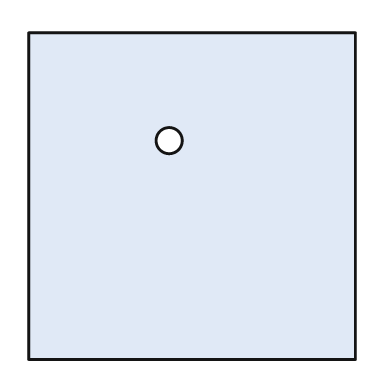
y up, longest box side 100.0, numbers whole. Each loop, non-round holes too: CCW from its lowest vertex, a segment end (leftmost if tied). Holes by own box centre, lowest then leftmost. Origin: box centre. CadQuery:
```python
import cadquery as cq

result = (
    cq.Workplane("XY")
    .moveTo(-50.0, -50.0)
    .lineTo(50.0, -50.0)
    .lineTo(50.0, 50.0)
    .lineTo(-50.0, 50.0)
    .close()
    .moveTo(-7.0, 17.0)
    .circle(4.0)
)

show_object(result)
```